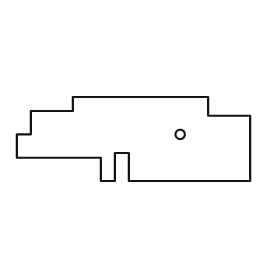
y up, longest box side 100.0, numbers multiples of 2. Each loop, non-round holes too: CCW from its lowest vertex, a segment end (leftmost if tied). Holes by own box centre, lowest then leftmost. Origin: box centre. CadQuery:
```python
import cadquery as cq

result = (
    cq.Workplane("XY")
    .moveTo(-14.0, -18.0)
    .lineTo(-8.0, -18.0)
    .lineTo(-8.0, -6.0)
    .lineTo(-2.0, -6.0)
    .lineTo(-2.0, -18.0)
    .lineTo(50.0, -18.0)
    .lineTo(50.0, 10.0)
    .lineTo(32.0, 10.0)
    .lineTo(32.0, 18.0)
    .lineTo(-26.0, 18.0)
    .lineTo(-26.0, 12.0)
    .lineTo(-44.0, 12.0)
    .lineTo(-44.0, 2.0)
    .lineTo(-50.0, 2.0)
    .lineTo(-50.0, -8.0)
    .lineTo(-14.0, -8.0)
    .close()
    .moveTo(20.0, 2.0)
    .circle(2.0)
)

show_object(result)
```